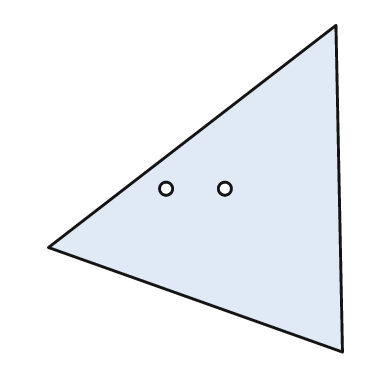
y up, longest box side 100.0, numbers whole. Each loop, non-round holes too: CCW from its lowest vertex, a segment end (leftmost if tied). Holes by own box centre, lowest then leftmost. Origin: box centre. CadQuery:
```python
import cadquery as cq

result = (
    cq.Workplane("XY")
    .moveTo(45.0, -50.0)
    .lineTo(43.0, 50.0)
    .lineTo(-45.0, -18.0)
    .close()
    .moveTo(-9.0, 0.0)
    .circle(2.0)
    .moveTo(9.0, 0.0)
    .circle(2.0)
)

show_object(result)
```